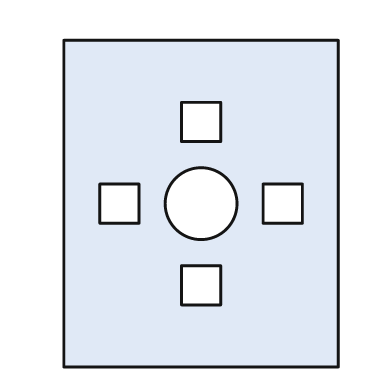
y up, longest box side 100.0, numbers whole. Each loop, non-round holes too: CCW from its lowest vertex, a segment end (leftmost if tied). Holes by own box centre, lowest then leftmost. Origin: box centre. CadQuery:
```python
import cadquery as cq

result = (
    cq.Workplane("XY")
    .moveTo(-42.0, -50.0)
    .lineTo(42.0, -50.0)
    .lineTo(42.0, 50.0)
    .lineTo(-42.0, 50.0)
    .close()
    .moveTo(-6.0, -31.0)
    .lineTo(6.0, -31.0)
    .lineTo(6.0, -19.0)
    .lineTo(-6.0, -19.0)
    .close()
    .moveTo(-31.0, -6.0)
    .lineTo(-19.0, -6.0)
    .lineTo(-19.0, 6.0)
    .lineTo(-31.0, 6.0)
    .close()
    .moveTo(0.0, 0.0)
    .circle(11.0)
    .moveTo(19.0, -6.0)
    .lineTo(31.0, -6.0)
    .lineTo(31.0, 6.0)
    .lineTo(19.0, 6.0)
    .close()
    .moveTo(-6.0, 19.0)
    .lineTo(6.0, 19.0)
    .lineTo(6.0, 31.0)
    .lineTo(-6.0, 31.0)
    .close()
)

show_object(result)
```